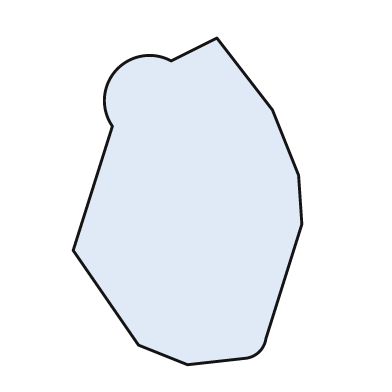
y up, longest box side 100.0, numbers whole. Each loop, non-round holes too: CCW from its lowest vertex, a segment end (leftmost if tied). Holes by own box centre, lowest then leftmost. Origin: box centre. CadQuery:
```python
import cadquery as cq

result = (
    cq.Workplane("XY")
    .moveTo(0.0, -50.0)
    .lineTo(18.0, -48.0)
    .threePointArc((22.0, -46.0), (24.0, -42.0))
    .lineTo(35.0, -7.0)
    .lineTo(34.0, 8.0)
    .lineTo(26.0, 28.0)
    .lineTo(9.0, 50.0)
    .lineTo(-5.0, 43.0)
    .threePointArc((-22.0, 40.0), (-23.0, 23.0))
    .lineTo(-35.0, -15.0)
    .lineTo(-15.0, -44.0)
    .close()
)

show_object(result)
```